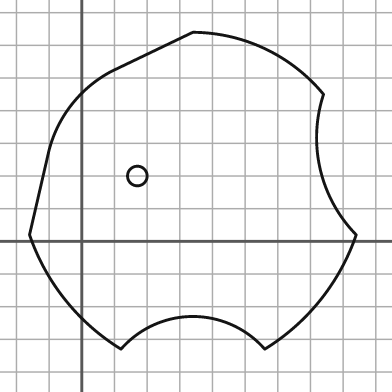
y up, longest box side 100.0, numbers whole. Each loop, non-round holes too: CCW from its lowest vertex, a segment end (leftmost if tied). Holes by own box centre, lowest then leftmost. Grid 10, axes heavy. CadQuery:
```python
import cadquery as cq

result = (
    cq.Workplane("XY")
    .moveTo(12.0, -33.0)
    .threePointArc((34.0, -23.0), (56.0, -33.0))
    .threePointArc((73.0, -18.0), (84.0, 2.0))
    .threePointArc((73.0, 22.0), (74.0, 45.0))
    .threePointArc((56.0, 59.0), (34.0, 64.0))
    .lineTo(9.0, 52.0)
    .threePointArc((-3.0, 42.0), (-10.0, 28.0))
    .lineTo(-16.0, 2.0)
    .threePointArc((-5.0, -18.0), (12.0, -33.0))
    .close()
    .moveTo(17.0, 20.0)
    .circle(3.0)
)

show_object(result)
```